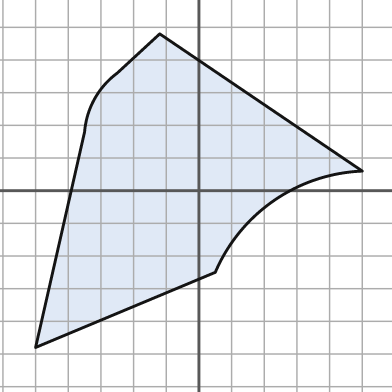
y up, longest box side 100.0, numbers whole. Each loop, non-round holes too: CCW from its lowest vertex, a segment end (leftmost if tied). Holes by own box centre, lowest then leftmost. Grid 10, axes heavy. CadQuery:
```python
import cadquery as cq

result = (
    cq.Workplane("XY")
    .moveTo(-50.0, -48.0)
    .lineTo(5.0, -25.0)
    .threePointArc((23.0, -3.0), (50.0, 6.0))
    .lineTo(-12.0, 48.0)
    .lineTo(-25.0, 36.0)
    .threePointArc((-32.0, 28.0), (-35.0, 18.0))
    .close()
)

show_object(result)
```